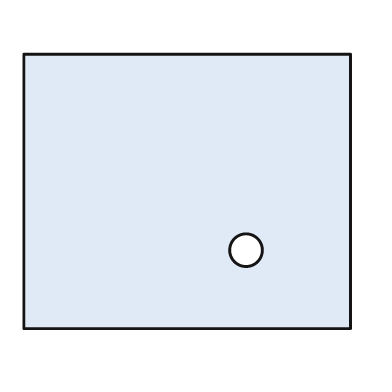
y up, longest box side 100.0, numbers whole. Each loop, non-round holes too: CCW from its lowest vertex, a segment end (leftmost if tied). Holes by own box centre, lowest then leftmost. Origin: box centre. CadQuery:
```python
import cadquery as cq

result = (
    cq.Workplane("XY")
    .moveTo(-50.0, -42.0)
    .lineTo(50.0, -42.0)
    .lineTo(50.0, 42.0)
    .lineTo(-50.0, 42.0)
    .close()
    .moveTo(18.0, -18.0)
    .circle(5.0)
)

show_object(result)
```